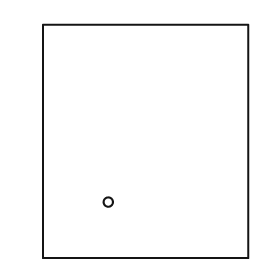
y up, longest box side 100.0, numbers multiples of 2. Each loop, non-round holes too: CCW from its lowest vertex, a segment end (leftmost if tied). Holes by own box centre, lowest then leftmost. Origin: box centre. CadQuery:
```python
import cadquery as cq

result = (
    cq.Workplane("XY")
    .moveTo(-44.0, -50.0)
    .lineTo(44.0, -50.0)
    .lineTo(44.0, 50.0)
    .lineTo(-44.0, 50.0)
    .close()
    .moveTo(-16.0, -26.0)
    .circle(2.0)
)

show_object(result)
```